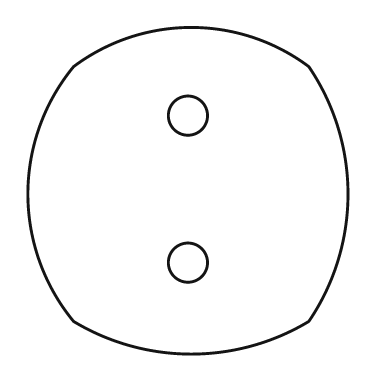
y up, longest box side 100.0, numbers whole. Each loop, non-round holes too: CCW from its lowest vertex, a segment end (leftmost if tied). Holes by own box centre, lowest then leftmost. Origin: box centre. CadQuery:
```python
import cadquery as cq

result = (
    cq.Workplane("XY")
    .moveTo(-35.0, -40.0)
    .threePointArc((1.0, -50.0), (37.0, -40.0))
    .threePointArc((49.0, -1.0), (37.0, 38.0))
    .threePointArc((1.0, 50.0), (-35.0, 38.0))
    .threePointArc((-49.0, -1.0), (-35.0, -40.0))
    .close()
    .moveTo(0.0, -22.0)
    .circle(6.0)
    .moveTo(0.0, 23.0)
    .circle(6.0)
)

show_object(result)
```